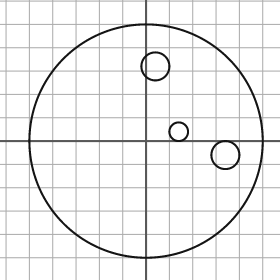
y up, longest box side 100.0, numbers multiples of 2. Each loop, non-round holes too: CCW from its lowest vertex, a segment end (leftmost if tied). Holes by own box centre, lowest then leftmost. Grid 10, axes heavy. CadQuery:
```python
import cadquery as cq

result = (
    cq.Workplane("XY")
    .moveTo(0.0, 0.0)
    .circle(50.0)
    .moveTo(34.0, -6.0)
    .circle(6.0)
    .moveTo(14.0, 4.0)
    .circle(4.0)
    .moveTo(4.0, 32.0)
    .circle(6.0)
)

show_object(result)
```